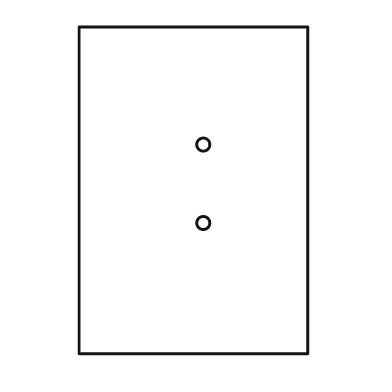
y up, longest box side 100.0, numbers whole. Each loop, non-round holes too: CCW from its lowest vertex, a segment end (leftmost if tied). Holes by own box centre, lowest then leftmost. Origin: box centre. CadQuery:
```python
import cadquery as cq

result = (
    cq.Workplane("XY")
    .moveTo(-35.0, -50.0)
    .lineTo(35.0, -50.0)
    .lineTo(35.0, 50.0)
    .lineTo(-35.0, 50.0)
    .close()
    .moveTo(3.0, -10.0)
    .circle(2.0)
    .moveTo(3.0, 14.0)
    .circle(2.0)
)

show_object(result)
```